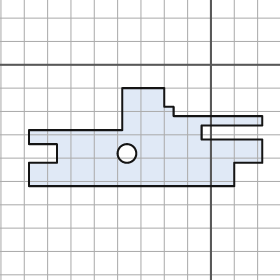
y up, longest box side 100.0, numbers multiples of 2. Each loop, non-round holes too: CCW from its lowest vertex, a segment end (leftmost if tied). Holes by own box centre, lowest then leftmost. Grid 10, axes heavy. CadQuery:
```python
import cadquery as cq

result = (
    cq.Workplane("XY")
    .moveTo(-78.0, -52.0)
    .lineTo(10.0, -52.0)
    .lineTo(10.0, -42.0)
    .lineTo(22.0, -42.0)
    .lineTo(22.0, -32.0)
    .lineTo(-4.0, -32.0)
    .lineTo(-4.0, -26.0)
    .lineTo(22.0, -26.0)
    .lineTo(22.0, -22.0)
    .lineTo(-16.0, -22.0)
    .lineTo(-16.0, -18.0)
    .lineTo(-20.0, -18.0)
    .lineTo(-20.0, -10.0)
    .lineTo(-38.0, -10.0)
    .lineTo(-38.0, -28.0)
    .lineTo(-78.0, -28.0)
    .lineTo(-78.0, -34.0)
    .lineTo(-66.0, -34.0)
    .lineTo(-66.0, -42.0)
    .lineTo(-78.0, -42.0)
    .close()
    .moveTo(-36.0, -38.0)
    .circle(4.0)
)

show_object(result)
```